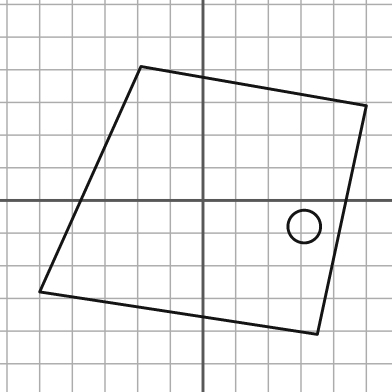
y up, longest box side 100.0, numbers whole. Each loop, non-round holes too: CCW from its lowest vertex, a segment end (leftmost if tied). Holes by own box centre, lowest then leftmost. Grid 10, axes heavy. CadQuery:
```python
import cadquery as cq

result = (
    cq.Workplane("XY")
    .moveTo(35.0, -41.0)
    .lineTo(50.0, 29.0)
    .lineTo(-19.0, 41.0)
    .lineTo(-50.0, -28.0)
    .close()
    .moveTo(31.0, -8.0)
    .circle(5.0)
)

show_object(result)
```